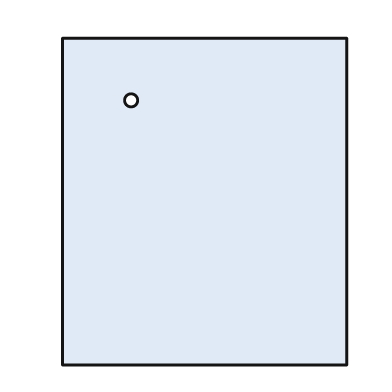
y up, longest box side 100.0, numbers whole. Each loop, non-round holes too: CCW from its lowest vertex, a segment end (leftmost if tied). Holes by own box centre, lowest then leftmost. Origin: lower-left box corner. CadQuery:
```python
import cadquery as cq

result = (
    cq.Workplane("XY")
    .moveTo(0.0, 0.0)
    .lineTo(87.0, 0.0)
    .lineTo(87.0, 100.0)
    .lineTo(0.0, 100.0)
    .close()
    .moveTo(21.0, 81.0)
    .circle(2.0)
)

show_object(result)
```